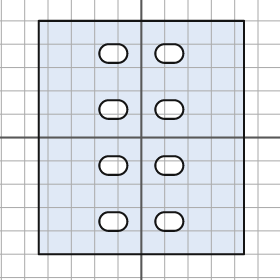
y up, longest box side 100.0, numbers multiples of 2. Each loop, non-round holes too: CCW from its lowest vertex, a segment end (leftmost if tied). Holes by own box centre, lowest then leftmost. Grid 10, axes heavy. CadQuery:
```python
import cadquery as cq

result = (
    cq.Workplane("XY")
    .moveTo(-44.0, -50.0)
    .lineTo(44.0, -50.0)
    .lineTo(44.0, 50.0)
    .lineTo(-44.0, 50.0)
    .close()
    .moveTo(-14.0, -40.0)
    .lineTo(-10.0, -40.0)
    .threePointArc((-6.0, -36.0), (-10.0, -32.0))
    .lineTo(-14.0, -32.0)
    .threePointArc((-18.0, -36.0), (-14.0, -40.0))
    .close()
    .moveTo(10.0, -40.0)
    .lineTo(14.0, -40.0)
    .threePointArc((18.0, -36.0), (14.0, -32.0))
    .lineTo(10.0, -32.0)
    .threePointArc((6.0, -36.0), (10.0, -40.0))
    .close()
    .moveTo(-14.0, -16.0)
    .lineTo(-10.0, -16.0)
    .threePointArc((-6.0, -12.0), (-10.0, -8.0))
    .lineTo(-14.0, -8.0)
    .threePointArc((-18.0, -12.0), (-14.0, -16.0))
    .close()
    .moveTo(10.0, -16.0)
    .lineTo(14.0, -16.0)
    .threePointArc((18.0, -12.0), (14.0, -8.0))
    .lineTo(10.0, -8.0)
    .threePointArc((6.0, -12.0), (10.0, -16.0))
    .close()
    .moveTo(-14.0, 8.0)
    .lineTo(-10.0, 8.0)
    .threePointArc((-6.0, 12.0), (-10.0, 16.0))
    .lineTo(-14.0, 16.0)
    .threePointArc((-18.0, 12.0), (-14.0, 8.0))
    .close()
    .moveTo(10.0, 8.0)
    .lineTo(14.0, 8.0)
    .threePointArc((18.0, 12.0), (14.0, 16.0))
    .lineTo(10.0, 16.0)
    .threePointArc((6.0, 12.0), (10.0, 8.0))
    .close()
    .moveTo(-14.0, 32.0)
    .lineTo(-10.0, 32.0)
    .threePointArc((-6.0, 36.0), (-10.0, 40.0))
    .lineTo(-14.0, 40.0)
    .threePointArc((-18.0, 36.0), (-14.0, 32.0))
    .close()
    .moveTo(10.0, 32.0)
    .lineTo(14.0, 32.0)
    .threePointArc((18.0, 36.0), (14.0, 40.0))
    .lineTo(10.0, 40.0)
    .threePointArc((6.0, 36.0), (10.0, 32.0))
    .close()
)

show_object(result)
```